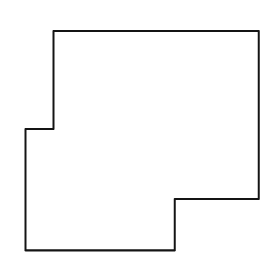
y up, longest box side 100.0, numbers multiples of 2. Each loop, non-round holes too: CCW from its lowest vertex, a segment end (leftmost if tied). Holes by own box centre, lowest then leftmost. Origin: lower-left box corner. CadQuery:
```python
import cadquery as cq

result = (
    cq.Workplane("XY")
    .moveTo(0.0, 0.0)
    .lineTo(64.0, 0.0)
    .lineTo(64.0, 22.0)
    .lineTo(100.0, 22.0)
    .lineTo(100.0, 94.0)
    .lineTo(12.0, 94.0)
    .lineTo(12.0, 52.0)
    .lineTo(0.0, 52.0)
    .close()
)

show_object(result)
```